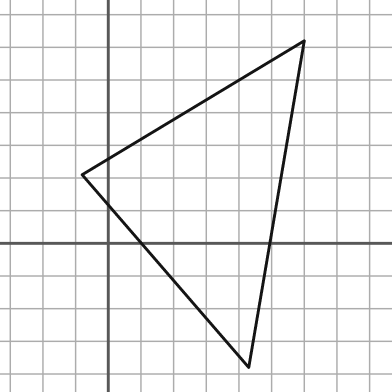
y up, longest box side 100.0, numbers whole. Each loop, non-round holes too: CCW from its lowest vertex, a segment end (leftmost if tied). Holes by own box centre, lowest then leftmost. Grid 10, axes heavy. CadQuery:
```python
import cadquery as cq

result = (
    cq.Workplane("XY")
    .moveTo(43.0, -38.0)
    .lineTo(60.0, 62.0)
    .lineTo(-8.0, 21.0)
    .close()
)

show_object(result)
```